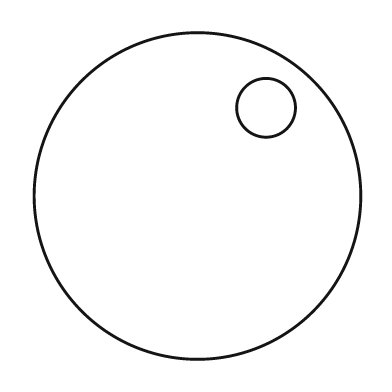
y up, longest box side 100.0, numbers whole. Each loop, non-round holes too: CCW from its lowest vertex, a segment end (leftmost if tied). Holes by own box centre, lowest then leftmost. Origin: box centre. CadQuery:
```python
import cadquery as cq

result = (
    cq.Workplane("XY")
    .moveTo(0.0, 0.0)
    .circle(50.0)
    .moveTo(21.0, 27.0)
    .circle(9.0)
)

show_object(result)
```